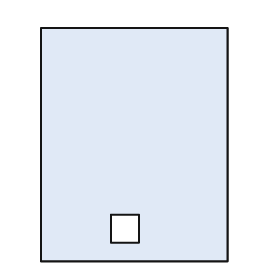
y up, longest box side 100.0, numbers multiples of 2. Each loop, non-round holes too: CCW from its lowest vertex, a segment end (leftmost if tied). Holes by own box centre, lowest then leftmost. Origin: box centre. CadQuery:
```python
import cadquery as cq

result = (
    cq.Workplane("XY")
    .moveTo(-40.0, -50.0)
    .lineTo(40.0, -50.0)
    .lineTo(40.0, 50.0)
    .lineTo(-40.0, 50.0)
    .close()
    .moveTo(-10.0, -42.0)
    .lineTo(2.0, -42.0)
    .lineTo(2.0, -30.0)
    .lineTo(-10.0, -30.0)
    .close()
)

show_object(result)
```